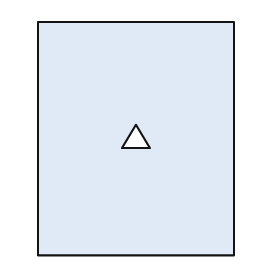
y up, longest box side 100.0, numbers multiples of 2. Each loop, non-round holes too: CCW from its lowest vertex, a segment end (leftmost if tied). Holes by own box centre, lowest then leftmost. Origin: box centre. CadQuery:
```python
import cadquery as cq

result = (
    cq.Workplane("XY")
    .moveTo(-42.0, -50.0)
    .lineTo(42.0, -50.0)
    .lineTo(42.0, 50.0)
    .lineTo(-42.0, 50.0)
    .close()
    .moveTo(-6.0, -4.0)
    .lineTo(6.0, -4.0)
    .lineTo(0.0, 6.0)
    .close()
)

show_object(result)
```